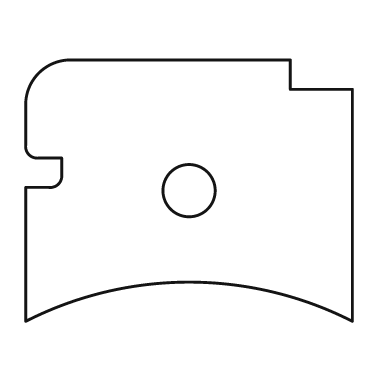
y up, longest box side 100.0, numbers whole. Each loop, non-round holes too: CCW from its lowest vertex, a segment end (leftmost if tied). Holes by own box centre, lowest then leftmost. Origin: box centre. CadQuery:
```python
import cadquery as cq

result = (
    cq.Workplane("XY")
    .moveTo(-50.0, -40.0)
    .threePointArc((0.0, -28.0), (50.0, -40.0))
    .lineTo(50.0, 31.0)
    .lineTo(31.0, 31.0)
    .lineTo(31.0, 40.0)
    .lineTo(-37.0, 40.0)
    .threePointArc((-46.0, 36.0), (-50.0, 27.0))
    .lineTo(-50.0, 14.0)
    .threePointArc((-49.0, 11.0), (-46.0, 10.0))
    .lineTo(-39.0, 10.0)
    .lineTo(-39.0, 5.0)
    .threePointArc((-40.0, 2.0), (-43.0, 1.0))
    .lineTo(-50.0, 1.0)
    .close()
    .moveTo(0.0, 0.0)
    .circle(8.0)
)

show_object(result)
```